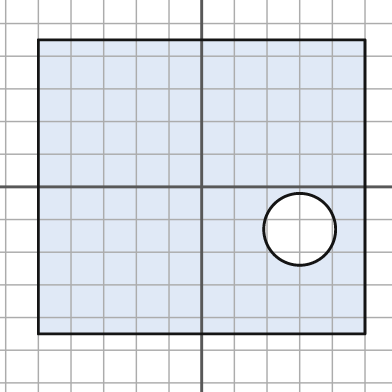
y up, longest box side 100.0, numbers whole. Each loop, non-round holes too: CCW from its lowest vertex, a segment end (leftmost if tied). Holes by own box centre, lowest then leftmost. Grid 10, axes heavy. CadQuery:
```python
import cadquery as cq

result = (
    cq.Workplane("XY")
    .moveTo(-50.0, -45.0)
    .lineTo(50.0, -45.0)
    .lineTo(50.0, 45.0)
    .lineTo(-50.0, 45.0)
    .close()
    .moveTo(30.0, -13.0)
    .circle(11.0)
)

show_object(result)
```